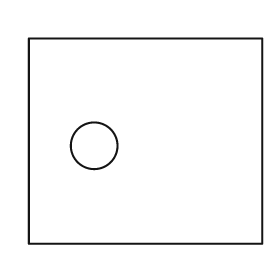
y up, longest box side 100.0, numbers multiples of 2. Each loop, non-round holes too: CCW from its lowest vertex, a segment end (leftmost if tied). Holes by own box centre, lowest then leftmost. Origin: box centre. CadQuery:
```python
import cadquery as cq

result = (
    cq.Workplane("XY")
    .moveTo(-50.0, -44.0)
    .lineTo(50.0, -44.0)
    .lineTo(50.0, 44.0)
    .lineTo(-50.0, 44.0)
    .close()
    .moveTo(-22.0, -2.0)
    .circle(10.0)
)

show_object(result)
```